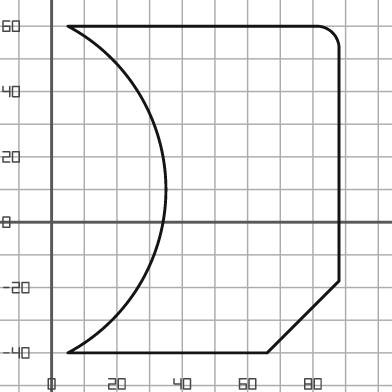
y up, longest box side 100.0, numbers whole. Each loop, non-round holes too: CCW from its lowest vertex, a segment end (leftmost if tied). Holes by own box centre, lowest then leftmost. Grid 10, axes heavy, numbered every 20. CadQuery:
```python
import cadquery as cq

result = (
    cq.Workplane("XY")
    .moveTo(5.0, -40.0)
    .lineTo(66.0, -40.0)
    .lineTo(88.0, -18.0)
    .lineTo(88.0, 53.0)
    .threePointArc((86.0, 58.0), (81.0, 60.0))
    .lineTo(5.0, 60.0)
    .threePointArc((35.0, 10.0), (5.0, -40.0))
    .close()
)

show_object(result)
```